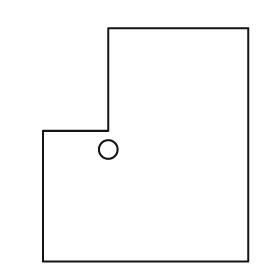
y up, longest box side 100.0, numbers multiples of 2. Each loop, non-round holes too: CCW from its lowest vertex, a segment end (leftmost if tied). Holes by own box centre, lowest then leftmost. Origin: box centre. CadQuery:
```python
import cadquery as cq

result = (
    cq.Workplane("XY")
    .moveTo(-44.0, -50.0)
    .lineTo(44.0, -50.0)
    .lineTo(44.0, 50.0)
    .lineTo(-16.0, 50.0)
    .lineTo(-16.0, 6.0)
    .lineTo(-44.0, 6.0)
    .close()
    .moveTo(-16.0, -2.0)
    .circle(4.0)
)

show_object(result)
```